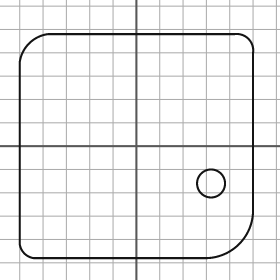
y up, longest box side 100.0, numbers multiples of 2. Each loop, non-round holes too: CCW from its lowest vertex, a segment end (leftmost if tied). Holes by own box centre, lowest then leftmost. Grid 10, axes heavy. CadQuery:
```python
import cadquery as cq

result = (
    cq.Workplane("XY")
    .moveTo(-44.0, -48.0)
    .lineTo(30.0, -48.0)
    .threePointArc((44.0, -42.0), (50.0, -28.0))
    .lineTo(50.0, 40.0)
    .threePointArc((48.0, 46.0), (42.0, 48.0))
    .lineTo(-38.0, 48.0)
    .threePointArc((-46.0, 44.0), (-50.0, 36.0))
    .lineTo(-50.0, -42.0)
    .threePointArc((-48.0, -46.0), (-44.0, -48.0))
    .close()
    .moveTo(32.0, -16.0)
    .circle(6.0)
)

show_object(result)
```